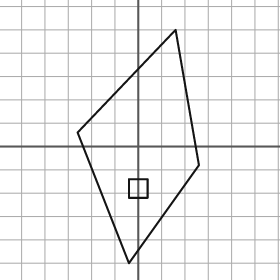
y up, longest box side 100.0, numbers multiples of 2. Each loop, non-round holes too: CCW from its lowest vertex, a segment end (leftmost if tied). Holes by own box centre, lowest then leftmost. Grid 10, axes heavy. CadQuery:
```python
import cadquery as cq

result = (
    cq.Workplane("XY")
    .moveTo(-4.0, -50.0)
    .lineTo(26.0, -8.0)
    .lineTo(16.0, 50.0)
    .lineTo(-26.0, 6.0)
    .close()
    .moveTo(-4.0, -22.0)
    .lineTo(4.0, -22.0)
    .lineTo(4.0, -14.0)
    .lineTo(-4.0, -14.0)
    .close()
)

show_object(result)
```